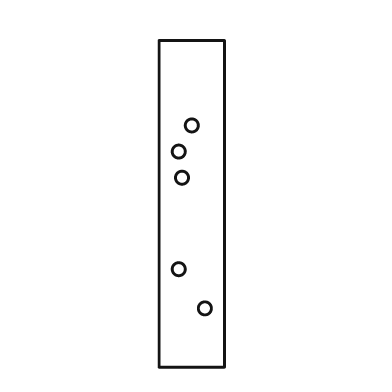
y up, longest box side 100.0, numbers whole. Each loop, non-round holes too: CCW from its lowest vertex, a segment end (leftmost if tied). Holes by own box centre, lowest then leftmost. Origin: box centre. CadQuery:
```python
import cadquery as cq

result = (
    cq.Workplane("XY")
    .moveTo(-10.0, -50.0)
    .lineTo(10.0, -50.0)
    .lineTo(10.0, 50.0)
    .lineTo(-10.0, 50.0)
    .close()
    .moveTo(4.0, -32.0)
    .circle(2.0)
    .moveTo(-4.0, -20.0)
    .circle(2.0)
    .moveTo(-3.0, 8.0)
    .circle(2.0)
    .moveTo(-4.0, 16.0)
    .circle(2.0)
    .moveTo(0.0, 24.0)
    .circle(2.0)
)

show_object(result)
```